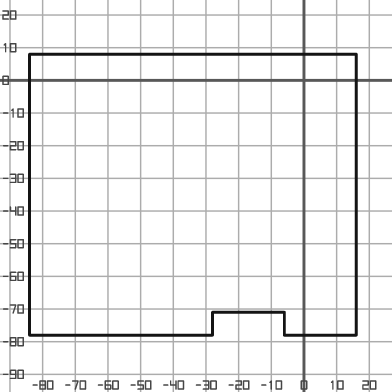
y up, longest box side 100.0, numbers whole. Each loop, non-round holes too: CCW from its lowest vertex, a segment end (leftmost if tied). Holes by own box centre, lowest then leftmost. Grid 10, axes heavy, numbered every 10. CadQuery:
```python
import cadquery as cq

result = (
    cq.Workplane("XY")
    .moveTo(-84.0, -78.0)
    .lineTo(-28.0, -78.0)
    .lineTo(-28.0, -71.0)
    .lineTo(-6.0, -71.0)
    .lineTo(-6.0, -78.0)
    .lineTo(16.0, -78.0)
    .lineTo(16.0, 8.0)
    .lineTo(-84.0, 8.0)
    .close()
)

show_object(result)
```